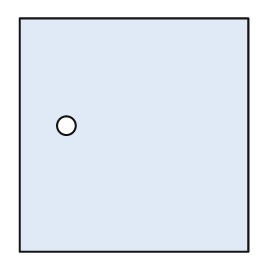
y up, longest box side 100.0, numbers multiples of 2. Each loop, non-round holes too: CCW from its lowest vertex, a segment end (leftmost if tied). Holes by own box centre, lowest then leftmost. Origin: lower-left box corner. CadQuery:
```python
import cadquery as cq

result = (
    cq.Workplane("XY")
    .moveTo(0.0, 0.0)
    .lineTo(98.0, 0.0)
    .lineTo(98.0, 100.0)
    .lineTo(0.0, 100.0)
    .close()
    .moveTo(20.0, 54.0)
    .circle(4.0)
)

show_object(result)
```